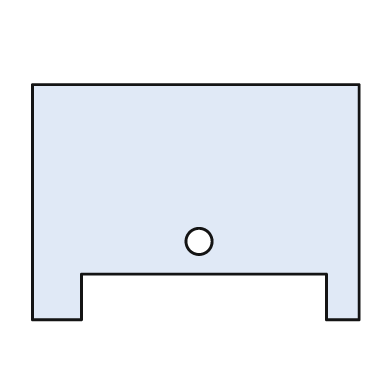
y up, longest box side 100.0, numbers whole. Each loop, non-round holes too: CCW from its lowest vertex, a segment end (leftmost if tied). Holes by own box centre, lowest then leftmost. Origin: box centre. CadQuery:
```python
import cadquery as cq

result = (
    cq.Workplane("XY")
    .moveTo(-50.0, -36.0)
    .lineTo(-35.0, -36.0)
    .lineTo(-35.0, -22.0)
    .lineTo(40.0, -22.0)
    .lineTo(40.0, -36.0)
    .lineTo(50.0, -36.0)
    .lineTo(50.0, 36.0)
    .lineTo(-50.0, 36.0)
    .close()
    .moveTo(1.0, -12.0)
    .circle(4.0)
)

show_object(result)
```